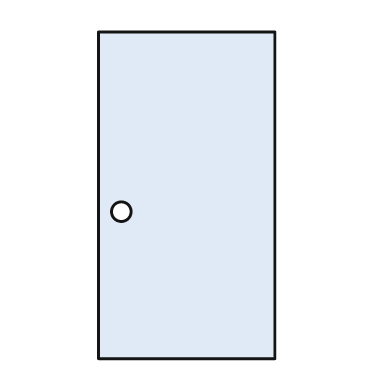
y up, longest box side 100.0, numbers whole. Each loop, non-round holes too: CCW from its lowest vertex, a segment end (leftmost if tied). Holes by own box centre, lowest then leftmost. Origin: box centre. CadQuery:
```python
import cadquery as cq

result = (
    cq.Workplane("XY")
    .moveTo(-27.0, -50.0)
    .lineTo(27.0, -50.0)
    .lineTo(27.0, 50.0)
    .lineTo(-27.0, 50.0)
    .close()
    .moveTo(-20.0, -5.0)
    .circle(3.0)
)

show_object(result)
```